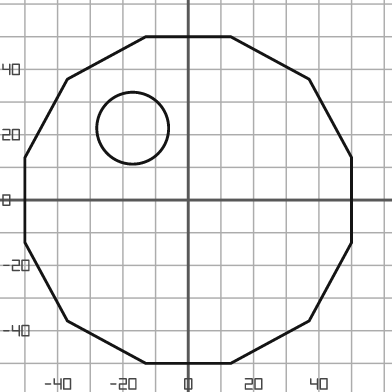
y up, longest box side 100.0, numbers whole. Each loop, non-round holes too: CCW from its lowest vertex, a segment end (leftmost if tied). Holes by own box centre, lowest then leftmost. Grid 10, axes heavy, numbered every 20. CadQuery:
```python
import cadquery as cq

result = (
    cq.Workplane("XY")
    .moveTo(-13.0, -50.0)
    .lineTo(13.0, -50.0)
    .lineTo(37.0, -37.0)
    .lineTo(50.0, -13.0)
    .lineTo(50.0, 13.0)
    .lineTo(37.0, 37.0)
    .lineTo(13.0, 50.0)
    .lineTo(-13.0, 50.0)
    .lineTo(-37.0, 37.0)
    .lineTo(-50.0, 13.0)
    .lineTo(-50.0, -13.0)
    .lineTo(-37.0, -37.0)
    .close()
    .moveTo(-17.0, 22.0)
    .circle(11.0)
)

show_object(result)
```